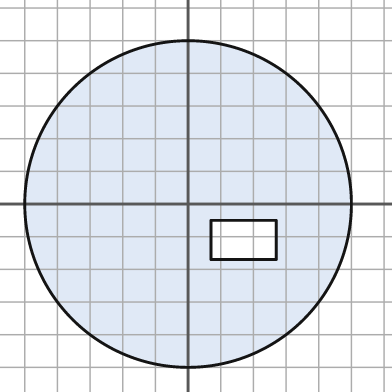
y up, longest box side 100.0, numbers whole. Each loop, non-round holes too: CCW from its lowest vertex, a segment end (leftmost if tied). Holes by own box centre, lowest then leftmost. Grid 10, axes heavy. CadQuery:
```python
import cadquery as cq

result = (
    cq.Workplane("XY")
    .moveTo(0.0, 0.0)
    .circle(50.0)
    .moveTo(7.0, -17.0)
    .lineTo(27.0, -17.0)
    .lineTo(27.0, -5.0)
    .lineTo(7.0, -5.0)
    .close()
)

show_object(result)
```